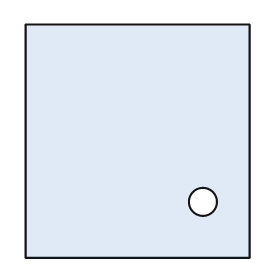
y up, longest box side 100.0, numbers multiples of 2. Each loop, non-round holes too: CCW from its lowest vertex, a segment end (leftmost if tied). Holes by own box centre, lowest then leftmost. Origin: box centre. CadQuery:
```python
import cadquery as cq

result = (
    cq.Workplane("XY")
    .moveTo(-48.0, -50.0)
    .lineTo(48.0, -50.0)
    .lineTo(48.0, 50.0)
    .lineTo(-48.0, 50.0)
    .close()
    .moveTo(28.0, -26.0)
    .circle(6.0)
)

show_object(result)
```